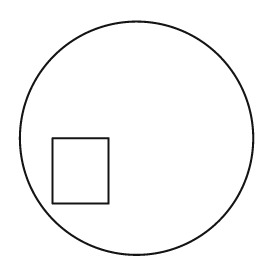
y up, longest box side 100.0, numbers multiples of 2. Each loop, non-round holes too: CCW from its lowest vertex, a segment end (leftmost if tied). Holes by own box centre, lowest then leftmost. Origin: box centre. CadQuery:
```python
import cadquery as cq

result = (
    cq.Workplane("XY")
    .moveTo(0.0, 0.0)
    .circle(50.0)
    .moveTo(-36.0, -28.0)
    .lineTo(-12.0, -28.0)
    .lineTo(-12.0, 0.0)
    .lineTo(-36.0, 0.0)
    .close()
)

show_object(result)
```